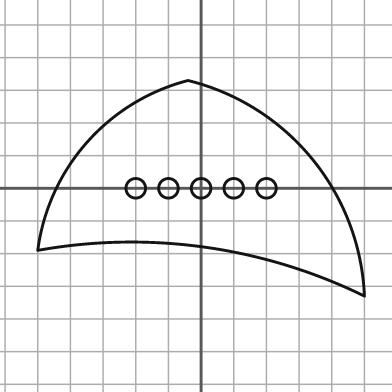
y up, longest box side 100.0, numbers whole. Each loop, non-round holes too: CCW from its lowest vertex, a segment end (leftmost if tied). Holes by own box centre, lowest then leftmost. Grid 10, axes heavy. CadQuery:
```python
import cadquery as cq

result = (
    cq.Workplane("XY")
    .moveTo(50.0, -33.0)
    .threePointArc((34.0, 9.0), (-4.0, 33.0))
    .threePointArc((-35.0, 14.0), (-50.0, -19.0))
    .threePointArc((1.0, -18.0), (50.0, -33.0))
    .close()
    .moveTo(-20.0, 0.0)
    .circle(3.0)
    .moveTo(-10.0, 0.0)
    .circle(3.0)
    .moveTo(0.0, 0.0)
    .circle(3.0)
    .moveTo(10.0, 0.0)
    .circle(3.0)
    .moveTo(20.0, 0.0)
    .circle(3.0)
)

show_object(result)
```